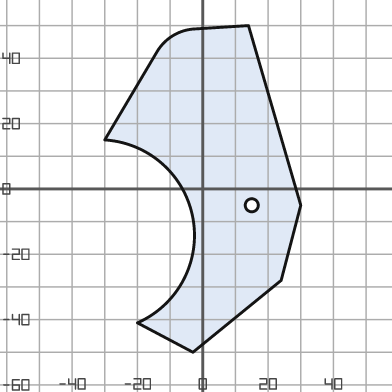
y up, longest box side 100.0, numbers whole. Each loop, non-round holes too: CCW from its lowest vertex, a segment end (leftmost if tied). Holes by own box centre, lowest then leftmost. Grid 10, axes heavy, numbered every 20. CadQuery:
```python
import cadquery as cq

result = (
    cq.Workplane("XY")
    .moveTo(-3.0, -50.0)
    .lineTo(24.0, -28.0)
    .lineTo(30.0, -5.0)
    .lineTo(14.0, 50.0)
    .lineTo(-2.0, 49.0)
    .threePointArc((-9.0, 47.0), (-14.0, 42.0))
    .lineTo(-30.0, 15.0)
    .threePointArc((-3.0, -9.0), (-20.0, -41.0))
    .close()
    .moveTo(15.0, -5.0)
    .circle(2.0)
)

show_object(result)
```